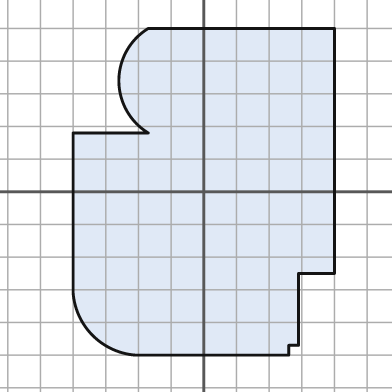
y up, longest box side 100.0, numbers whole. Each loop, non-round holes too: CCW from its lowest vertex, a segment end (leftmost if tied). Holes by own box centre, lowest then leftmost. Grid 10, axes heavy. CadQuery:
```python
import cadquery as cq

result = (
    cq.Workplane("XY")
    .moveTo(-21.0, -50.0)
    .lineTo(26.0, -50.0)
    .lineTo(26.0, -47.0)
    .lineTo(29.0, -47.0)
    .lineTo(29.0, -25.0)
    .lineTo(40.0, -25.0)
    .lineTo(40.0, 50.0)
    .lineTo(-17.0, 50.0)
    .threePointArc((-26.0, 34.0), (-17.0, 18.0))
    .lineTo(-40.0, 18.0)
    .lineTo(-40.0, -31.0)
    .threePointArc((-34.0, -44.0), (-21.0, -50.0))
    .close()
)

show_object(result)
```